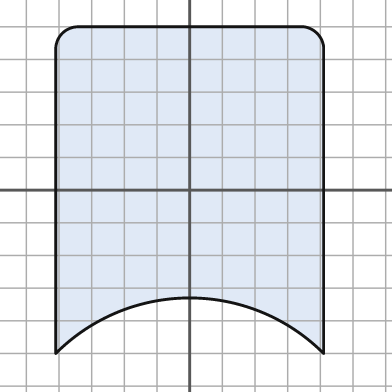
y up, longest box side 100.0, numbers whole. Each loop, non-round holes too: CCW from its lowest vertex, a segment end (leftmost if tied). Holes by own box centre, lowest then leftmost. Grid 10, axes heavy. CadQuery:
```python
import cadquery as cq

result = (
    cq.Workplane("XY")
    .moveTo(-41.0, -50.0)
    .threePointArc((0.0, -33.0), (41.0, -50.0))
    .lineTo(41.0, 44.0)
    .threePointArc((39.0, 48.0), (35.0, 50.0))
    .lineTo(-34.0, 50.0)
    .threePointArc((-39.0, 48.0), (-41.0, 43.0))
    .close()
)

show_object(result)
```